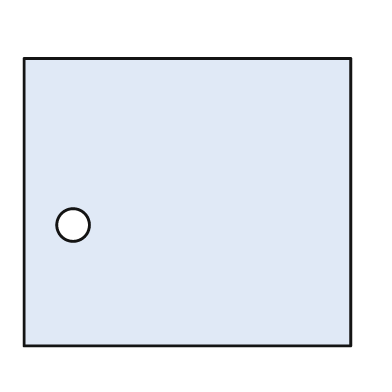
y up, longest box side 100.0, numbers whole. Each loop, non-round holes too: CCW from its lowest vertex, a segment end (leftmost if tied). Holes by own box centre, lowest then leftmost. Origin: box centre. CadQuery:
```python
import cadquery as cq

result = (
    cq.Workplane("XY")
    .moveTo(-50.0, -44.0)
    .lineTo(50.0, -44.0)
    .lineTo(50.0, 44.0)
    .lineTo(-50.0, 44.0)
    .close()
    .moveTo(-35.0, -7.0)
    .circle(5.0)
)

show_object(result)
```